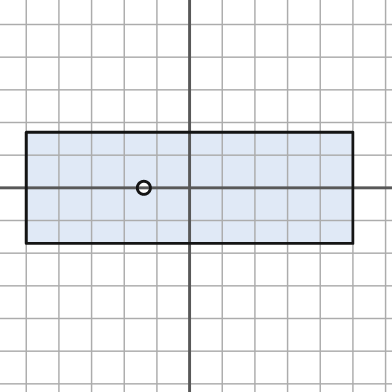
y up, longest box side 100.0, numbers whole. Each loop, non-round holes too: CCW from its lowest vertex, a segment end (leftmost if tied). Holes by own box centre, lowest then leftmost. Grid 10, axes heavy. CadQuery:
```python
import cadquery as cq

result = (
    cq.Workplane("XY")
    .moveTo(-50.0, -17.0)
    .lineTo(50.0, -17.0)
    .lineTo(50.0, 17.0)
    .lineTo(-50.0, 17.0)
    .close()
    .moveTo(-14.0, 0.0)
    .circle(2.0)
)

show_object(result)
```